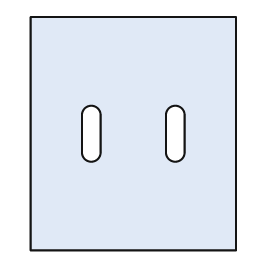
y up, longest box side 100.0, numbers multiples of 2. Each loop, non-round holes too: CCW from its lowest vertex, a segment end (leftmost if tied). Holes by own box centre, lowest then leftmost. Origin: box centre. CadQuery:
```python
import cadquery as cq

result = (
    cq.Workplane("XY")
    .moveTo(-44.0, -50.0)
    .lineTo(44.0, -50.0)
    .lineTo(44.0, 50.0)
    .lineTo(-44.0, 50.0)
    .close()
    .moveTo(-22.0, -8.0)
    .threePointArc((-18.0, -12.0), (-14.0, -8.0))
    .lineTo(-14.0, 8.0)
    .threePointArc((-18.0, 12.0), (-22.0, 8.0))
    .close()
    .moveTo(14.0, -8.0)
    .threePointArc((18.0, -12.0), (22.0, -8.0))
    .lineTo(22.0, 8.0)
    .threePointArc((18.0, 12.0), (14.0, 8.0))
    .close()
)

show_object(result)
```